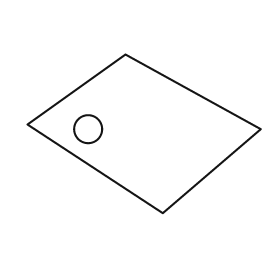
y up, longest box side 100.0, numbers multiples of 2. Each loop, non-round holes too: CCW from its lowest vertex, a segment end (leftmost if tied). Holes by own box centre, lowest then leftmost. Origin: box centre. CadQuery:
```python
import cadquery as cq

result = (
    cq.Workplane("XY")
    .moveTo(8.0, -34.0)
    .lineTo(50.0, 2.0)
    .lineTo(-8.0, 34.0)
    .lineTo(-50.0, 4.0)
    .close()
    .moveTo(-24.0, 2.0)
    .circle(6.0)
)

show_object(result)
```